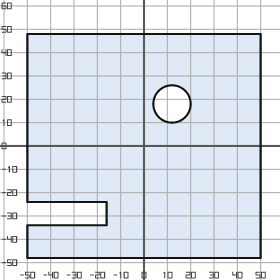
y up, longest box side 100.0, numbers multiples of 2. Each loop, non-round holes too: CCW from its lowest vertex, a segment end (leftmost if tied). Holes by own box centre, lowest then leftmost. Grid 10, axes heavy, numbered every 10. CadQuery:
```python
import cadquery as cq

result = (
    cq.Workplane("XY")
    .moveTo(-50.0, -48.0)
    .lineTo(50.0, -48.0)
    .lineTo(50.0, 48.0)
    .lineTo(-50.0, 48.0)
    .lineTo(-50.0, -24.0)
    .lineTo(-16.0, -24.0)
    .lineTo(-16.0, -34.0)
    .lineTo(-50.0, -34.0)
    .close()
    .moveTo(12.0, 18.0)
    .circle(8.0)
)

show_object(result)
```